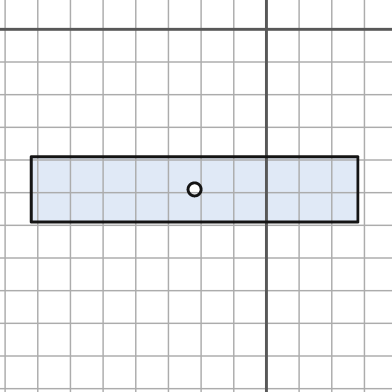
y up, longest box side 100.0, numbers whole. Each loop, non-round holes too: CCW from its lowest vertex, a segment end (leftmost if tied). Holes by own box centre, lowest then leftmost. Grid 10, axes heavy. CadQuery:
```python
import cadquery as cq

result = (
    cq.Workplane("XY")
    .moveTo(-72.0, -59.0)
    .lineTo(28.0, -59.0)
    .lineTo(28.0, -39.0)
    .lineTo(-72.0, -39.0)
    .close()
    .moveTo(-22.0, -49.0)
    .circle(2.0)
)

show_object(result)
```